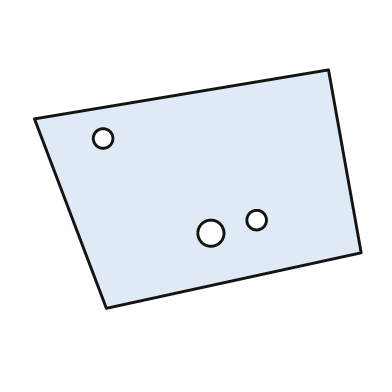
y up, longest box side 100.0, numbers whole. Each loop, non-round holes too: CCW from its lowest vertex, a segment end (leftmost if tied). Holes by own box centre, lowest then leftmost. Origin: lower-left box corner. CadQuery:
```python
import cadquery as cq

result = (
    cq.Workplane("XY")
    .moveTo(22.0, 0.0)
    .lineTo(100.0, 17.0)
    .lineTo(90.0, 73.0)
    .lineTo(0.0, 58.0)
    .close()
    .moveTo(54.0, 23.0)
    .circle(4.0)
    .moveTo(68.0, 27.0)
    .circle(3.0)
    .moveTo(21.0, 52.0)
    .circle(3.0)
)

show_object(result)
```